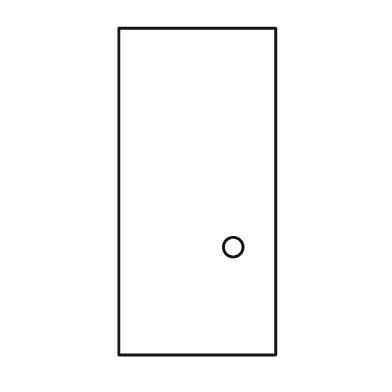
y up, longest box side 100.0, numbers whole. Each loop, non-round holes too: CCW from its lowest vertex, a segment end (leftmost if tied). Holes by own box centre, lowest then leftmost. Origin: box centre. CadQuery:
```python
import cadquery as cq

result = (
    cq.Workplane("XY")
    .moveTo(-24.0, -50.0)
    .lineTo(24.0, -50.0)
    .lineTo(24.0, 50.0)
    .lineTo(-24.0, 50.0)
    .close()
    .moveTo(11.0, -17.0)
    .circle(3.0)
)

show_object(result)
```